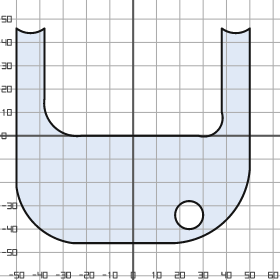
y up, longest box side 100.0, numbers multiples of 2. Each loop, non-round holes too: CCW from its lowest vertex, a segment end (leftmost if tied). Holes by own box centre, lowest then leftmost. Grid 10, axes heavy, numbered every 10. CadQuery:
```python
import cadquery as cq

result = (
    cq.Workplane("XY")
    .moveTo(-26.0, -46.0)
    .lineTo(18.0, -46.0)
    .threePointArc((40.0, -36.0), (50.0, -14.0))
    .lineTo(50.0, 46.0)
    .threePointArc((44.0, 44.0), (38.0, 46.0))
    .lineTo(38.0, 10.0)
    .threePointArc((36.0, 2.0), (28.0, 0.0))
    .lineTo(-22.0, 0.0)
    .threePointArc((-34.0, 4.0), (-38.0, 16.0))
    .lineTo(-38.0, 46.0)
    .threePointArc((-44.0, 44.0), (-50.0, 46.0))
    .lineTo(-50.0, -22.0)
    .threePointArc((-42.0, -38.0), (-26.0, -46.0))
    .close()
    .moveTo(24.0, -34.0)
    .circle(6.0)
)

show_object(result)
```